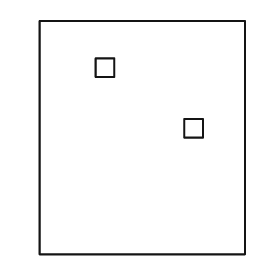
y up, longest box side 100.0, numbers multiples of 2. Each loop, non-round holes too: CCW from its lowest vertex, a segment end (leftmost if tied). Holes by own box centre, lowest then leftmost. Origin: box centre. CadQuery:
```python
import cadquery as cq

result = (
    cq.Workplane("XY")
    .moveTo(-44.0, -50.0)
    .lineTo(44.0, -50.0)
    .lineTo(44.0, 50.0)
    .lineTo(-44.0, 50.0)
    .close()
    .moveTo(18.0, 0.0)
    .lineTo(26.0, 0.0)
    .lineTo(26.0, 8.0)
    .lineTo(18.0, 8.0)
    .close()
    .moveTo(-20.0, 26.0)
    .lineTo(-12.0, 26.0)
    .lineTo(-12.0, 34.0)
    .lineTo(-20.0, 34.0)
    .close()
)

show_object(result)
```